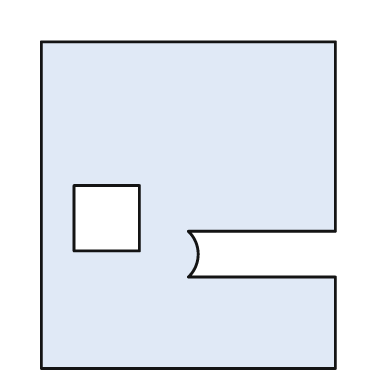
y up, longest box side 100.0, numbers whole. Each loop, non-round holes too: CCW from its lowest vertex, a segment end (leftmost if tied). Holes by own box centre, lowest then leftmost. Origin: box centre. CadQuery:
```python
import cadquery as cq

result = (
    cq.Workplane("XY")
    .moveTo(-45.0, -50.0)
    .lineTo(45.0, -50.0)
    .lineTo(45.0, -22.0)
    .lineTo(0.0, -22.0)
    .threePointArc((3.0, -15.0), (0.0, -8.0))
    .lineTo(45.0, -8.0)
    .lineTo(45.0, 50.0)
    .lineTo(-45.0, 50.0)
    .close()
    .moveTo(-35.0, -14.0)
    .lineTo(-15.0, -14.0)
    .lineTo(-15.0, 6.0)
    .lineTo(-35.0, 6.0)
    .close()
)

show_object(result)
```